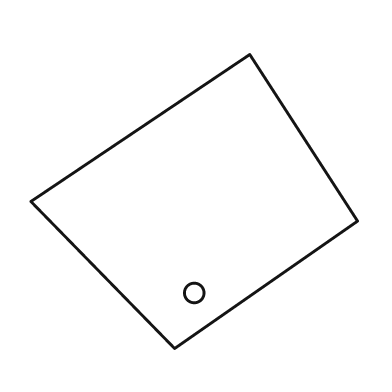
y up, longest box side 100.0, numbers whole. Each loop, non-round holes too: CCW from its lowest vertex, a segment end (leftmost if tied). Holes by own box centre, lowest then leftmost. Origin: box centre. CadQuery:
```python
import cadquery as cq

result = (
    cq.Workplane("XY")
    .moveTo(-6.0, -45.0)
    .lineTo(50.0, -6.0)
    .lineTo(17.0, 45.0)
    .lineTo(-50.0, 0.0)
    .close()
    .moveTo(0.0, -28.0)
    .circle(3.0)
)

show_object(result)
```